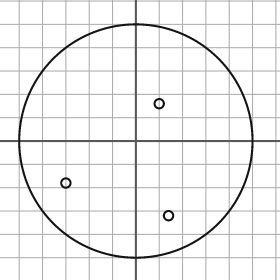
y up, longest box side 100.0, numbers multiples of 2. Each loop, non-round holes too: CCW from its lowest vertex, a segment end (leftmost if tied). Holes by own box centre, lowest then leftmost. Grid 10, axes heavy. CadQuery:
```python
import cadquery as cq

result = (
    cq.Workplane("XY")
    .moveTo(0.0, 0.0)
    .circle(50.0)
    .moveTo(14.0, -32.0)
    .circle(2.0)
    .moveTo(-30.0, -18.0)
    .circle(2.0)
    .moveTo(10.0, 16.0)
    .circle(2.0)
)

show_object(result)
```